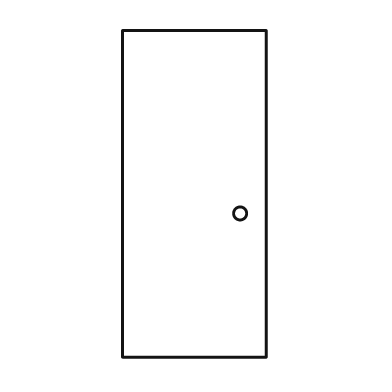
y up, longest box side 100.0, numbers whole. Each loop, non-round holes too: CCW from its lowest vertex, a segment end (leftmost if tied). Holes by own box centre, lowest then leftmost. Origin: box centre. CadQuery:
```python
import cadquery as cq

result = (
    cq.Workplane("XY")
    .moveTo(-22.0, -50.0)
    .lineTo(22.0, -50.0)
    .lineTo(22.0, 50.0)
    .lineTo(-22.0, 50.0)
    .close()
    .moveTo(14.0, -6.0)
    .circle(2.0)
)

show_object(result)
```